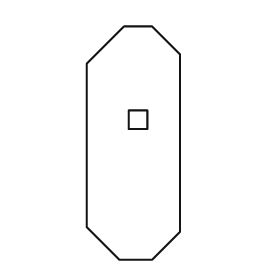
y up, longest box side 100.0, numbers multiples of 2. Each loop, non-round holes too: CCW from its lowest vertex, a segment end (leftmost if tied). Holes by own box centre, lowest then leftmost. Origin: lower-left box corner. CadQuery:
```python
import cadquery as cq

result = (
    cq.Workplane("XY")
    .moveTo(14.0, 0.0)
    .lineTo(28.0, 0.0)
    .lineTo(40.0, 12.0)
    .lineTo(40.0, 88.0)
    .lineTo(28.0, 100.0)
    .lineTo(16.0, 100.0)
    .lineTo(0.0, 84.0)
    .lineTo(0.0, 14.0)
    .close()
    .moveTo(18.0, 56.0)
    .lineTo(26.0, 56.0)
    .lineTo(26.0, 64.0)
    .lineTo(18.0, 64.0)
    .close()
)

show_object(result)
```